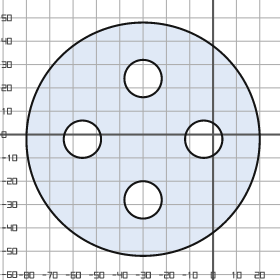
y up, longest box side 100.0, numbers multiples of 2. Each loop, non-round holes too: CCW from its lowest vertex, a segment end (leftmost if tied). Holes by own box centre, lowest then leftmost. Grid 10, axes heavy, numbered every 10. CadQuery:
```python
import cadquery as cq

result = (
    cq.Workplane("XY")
    .moveTo(-30.0, -2.0)
    .circle(50.0)
    .moveTo(-30.0, -28.0)
    .circle(8.0)
    .moveTo(-56.0, -2.0)
    .circle(8.0)
    .moveTo(-4.0, -2.0)
    .circle(8.0)
    .moveTo(-30.0, 24.0)
    .circle(8.0)
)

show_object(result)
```